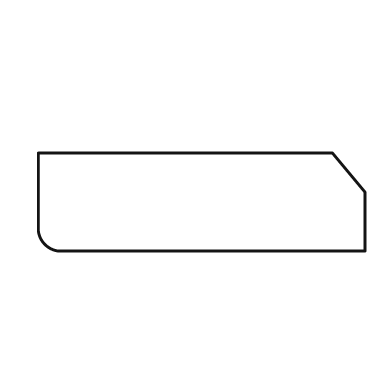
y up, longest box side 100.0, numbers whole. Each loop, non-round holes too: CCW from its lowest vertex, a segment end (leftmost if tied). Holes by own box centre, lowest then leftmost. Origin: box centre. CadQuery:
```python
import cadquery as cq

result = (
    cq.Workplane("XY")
    .moveTo(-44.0, -15.0)
    .lineTo(50.0, -15.0)
    .lineTo(50.0, 3.0)
    .lineTo(40.0, 15.0)
    .lineTo(-50.0, 15.0)
    .lineTo(-50.0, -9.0)
    .threePointArc((-48.0, -13.0), (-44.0, -15.0))
    .close()
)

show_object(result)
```